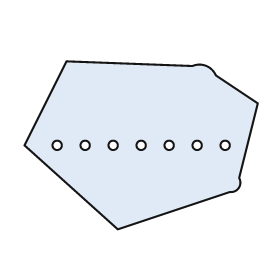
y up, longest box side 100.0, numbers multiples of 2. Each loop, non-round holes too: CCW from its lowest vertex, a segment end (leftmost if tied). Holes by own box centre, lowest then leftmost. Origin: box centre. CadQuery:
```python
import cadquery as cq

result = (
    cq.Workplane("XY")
    .moveTo(-10.0, -36.0)
    .lineTo(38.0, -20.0)
    .threePointArc((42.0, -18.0), (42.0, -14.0))
    .lineTo(50.0, 18.0)
    .lineTo(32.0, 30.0)
    .threePointArc((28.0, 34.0), (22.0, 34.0))
    .lineTo(-32.0, 36.0)
    .lineTo(-50.0, 0.0)
    .close()
    .moveTo(-36.0, 0.0)
    .circle(2.0)
    .moveTo(-24.0, 0.0)
    .circle(2.0)
    .moveTo(-12.0, 0.0)
    .circle(2.0)
    .moveTo(0.0, 0.0)
    .circle(2.0)
    .moveTo(12.0, 0.0)
    .circle(2.0)
    .moveTo(24.0, 0.0)
    .circle(2.0)
    .moveTo(36.0, 0.0)
    .circle(2.0)
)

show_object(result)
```